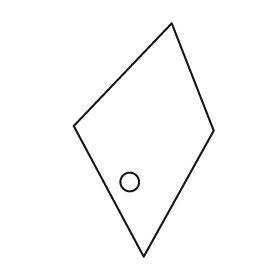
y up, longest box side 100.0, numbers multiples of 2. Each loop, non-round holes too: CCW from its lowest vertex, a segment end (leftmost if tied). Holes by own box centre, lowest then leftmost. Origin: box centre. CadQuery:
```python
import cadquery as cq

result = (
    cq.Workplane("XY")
    .moveTo(0.0, -50.0)
    .lineTo(30.0, 4.0)
    .lineTo(12.0, 50.0)
    .lineTo(-30.0, 6.0)
    .close()
    .moveTo(-6.0, -18.0)
    .circle(4.0)
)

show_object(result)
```